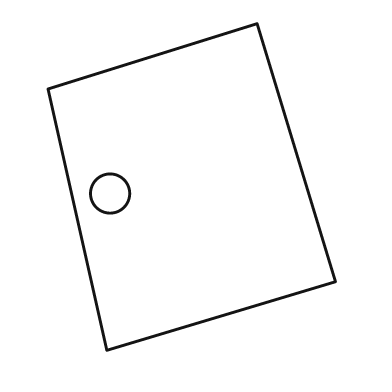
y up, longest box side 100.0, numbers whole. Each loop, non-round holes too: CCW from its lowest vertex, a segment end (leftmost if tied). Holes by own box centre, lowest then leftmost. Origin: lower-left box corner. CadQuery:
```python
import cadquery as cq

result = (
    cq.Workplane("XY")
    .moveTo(18.0, 0.0)
    .lineTo(88.0, 21.0)
    .lineTo(64.0, 100.0)
    .lineTo(0.0, 80.0)
    .close()
    .moveTo(19.0, 48.0)
    .circle(6.0)
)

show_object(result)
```